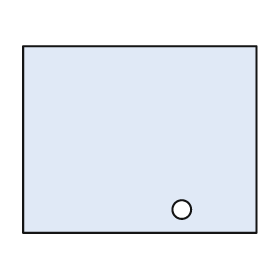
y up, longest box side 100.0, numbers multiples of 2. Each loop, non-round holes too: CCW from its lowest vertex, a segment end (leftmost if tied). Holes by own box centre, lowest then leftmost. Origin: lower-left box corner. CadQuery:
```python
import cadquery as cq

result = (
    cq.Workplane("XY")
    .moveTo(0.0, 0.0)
    .lineTo(100.0, 0.0)
    .lineTo(100.0, 80.0)
    .lineTo(0.0, 80.0)
    .close()
    .moveTo(68.0, 10.0)
    .circle(4.0)
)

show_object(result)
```